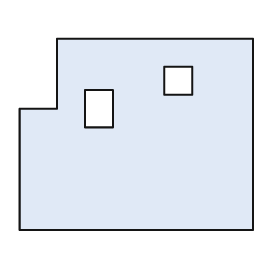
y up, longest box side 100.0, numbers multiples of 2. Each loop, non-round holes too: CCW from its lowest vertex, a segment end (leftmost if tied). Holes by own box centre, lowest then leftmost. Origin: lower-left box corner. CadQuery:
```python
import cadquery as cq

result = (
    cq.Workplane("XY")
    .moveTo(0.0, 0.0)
    .lineTo(100.0, 0.0)
    .lineTo(100.0, 82.0)
    .lineTo(16.0, 82.0)
    .lineTo(16.0, 52.0)
    .lineTo(0.0, 52.0)
    .close()
    .moveTo(28.0, 44.0)
    .lineTo(40.0, 44.0)
    .lineTo(40.0, 60.0)
    .lineTo(28.0, 60.0)
    .close()
    .moveTo(62.0, 58.0)
    .lineTo(74.0, 58.0)
    .lineTo(74.0, 70.0)
    .lineTo(62.0, 70.0)
    .close()
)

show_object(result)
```